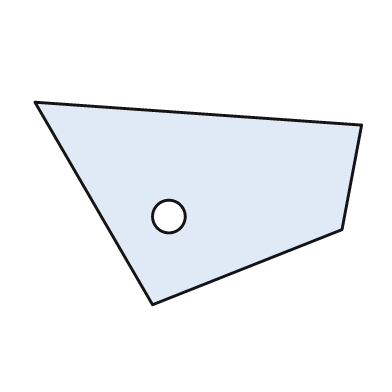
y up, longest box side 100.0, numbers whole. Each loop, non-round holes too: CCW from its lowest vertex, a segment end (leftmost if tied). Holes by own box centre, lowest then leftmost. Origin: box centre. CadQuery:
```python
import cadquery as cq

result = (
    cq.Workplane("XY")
    .moveTo(-14.0, -31.0)
    .lineTo(44.0, -8.0)
    .lineTo(50.0, 24.0)
    .lineTo(-50.0, 31.0)
    .close()
    .moveTo(-9.0, -4.0)
    .circle(5.0)
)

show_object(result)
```